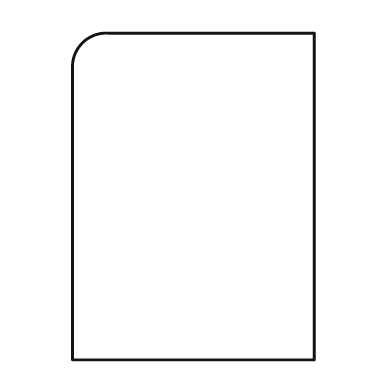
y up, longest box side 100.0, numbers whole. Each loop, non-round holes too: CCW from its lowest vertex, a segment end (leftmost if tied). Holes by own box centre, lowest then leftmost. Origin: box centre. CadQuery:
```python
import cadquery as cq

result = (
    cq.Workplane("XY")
    .moveTo(-37.0, -50.0)
    .lineTo(37.0, -50.0)
    .lineTo(37.0, 50.0)
    .lineTo(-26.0, 50.0)
    .threePointArc((-34.0, 47.0), (-37.0, 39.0))
    .close()
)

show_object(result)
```